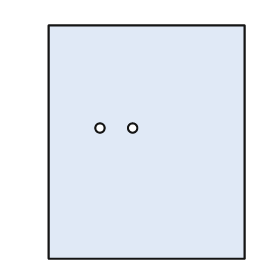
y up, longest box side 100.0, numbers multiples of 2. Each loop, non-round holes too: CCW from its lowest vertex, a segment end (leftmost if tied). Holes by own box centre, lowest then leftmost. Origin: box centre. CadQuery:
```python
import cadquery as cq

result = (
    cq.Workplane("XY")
    .moveTo(-42.0, -50.0)
    .lineTo(42.0, -50.0)
    .lineTo(42.0, 50.0)
    .lineTo(-42.0, 50.0)
    .close()
    .moveTo(-20.0, 6.0)
    .circle(2.0)
    .moveTo(-6.0, 6.0)
    .circle(2.0)
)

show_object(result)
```